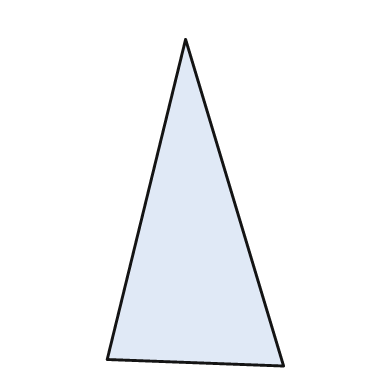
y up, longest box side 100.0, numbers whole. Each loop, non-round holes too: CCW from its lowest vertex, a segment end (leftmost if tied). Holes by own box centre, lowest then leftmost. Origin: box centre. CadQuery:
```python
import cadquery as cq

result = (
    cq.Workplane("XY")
    .moveTo(27.0, -50.0)
    .lineTo(-3.0, 50.0)
    .lineTo(-27.0, -48.0)
    .close()
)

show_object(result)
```